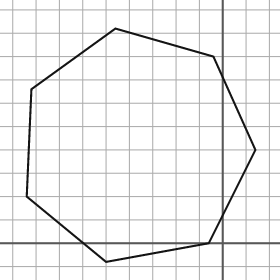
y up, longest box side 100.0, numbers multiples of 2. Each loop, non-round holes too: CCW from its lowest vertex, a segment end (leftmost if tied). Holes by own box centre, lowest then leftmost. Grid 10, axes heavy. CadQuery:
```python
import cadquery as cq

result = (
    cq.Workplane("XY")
    .moveTo(-50.0, -8.0)
    .lineTo(-6.0, 0.0)
    .lineTo(14.0, 40.0)
    .lineTo(-4.0, 80.0)
    .lineTo(-46.0, 92.0)
    .lineTo(-82.0, 66.0)
    .lineTo(-84.0, 20.0)
    .close()
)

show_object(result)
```